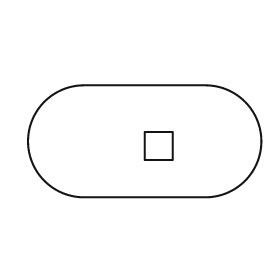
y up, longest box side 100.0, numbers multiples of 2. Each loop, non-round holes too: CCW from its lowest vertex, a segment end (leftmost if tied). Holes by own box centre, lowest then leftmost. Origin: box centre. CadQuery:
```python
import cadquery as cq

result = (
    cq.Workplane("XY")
    .moveTo(-26.0, -24.0)
    .lineTo(26.0, -24.0)
    .threePointArc((50.0, 0.0), (26.0, 24.0))
    .lineTo(-26.0, 24.0)
    .threePointArc((-50.0, 0.0), (-26.0, -24.0))
    .close()
    .moveTo(0.0, -8.0)
    .lineTo(12.0, -8.0)
    .lineTo(12.0, 4.0)
    .lineTo(0.0, 4.0)
    .close()
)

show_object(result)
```